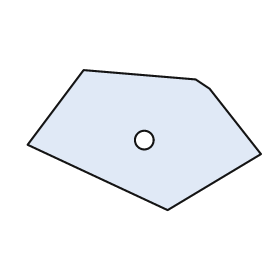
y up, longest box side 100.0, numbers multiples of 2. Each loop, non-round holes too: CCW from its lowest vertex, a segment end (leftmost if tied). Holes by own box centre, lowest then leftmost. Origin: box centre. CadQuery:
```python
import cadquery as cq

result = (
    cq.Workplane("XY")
    .moveTo(10.0, -30.0)
    .lineTo(50.0, -6.0)
    .lineTo(28.0, 22.0)
    .lineTo(22.0, 26.0)
    .lineTo(-26.0, 30.0)
    .lineTo(-50.0, -2.0)
    .close()
    .moveTo(0.0, 0.0)
    .circle(4.0)
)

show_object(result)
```